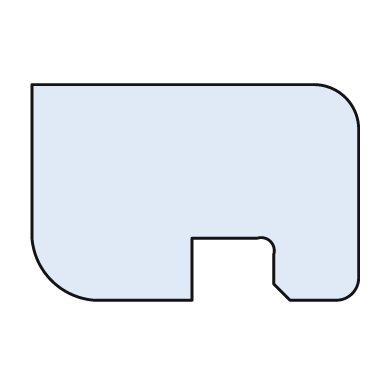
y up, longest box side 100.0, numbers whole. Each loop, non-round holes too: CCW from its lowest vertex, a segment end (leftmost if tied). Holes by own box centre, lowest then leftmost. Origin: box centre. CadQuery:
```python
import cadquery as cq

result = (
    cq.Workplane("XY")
    .moveTo(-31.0, -33.0)
    .lineTo(-1.0, -33.0)
    .lineTo(-1.0, -14.0)
    .lineTo(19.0, -14.0)
    .threePointArc((23.0, -15.0), (24.0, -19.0))
    .lineTo(24.0, -28.0)
    .lineTo(29.0, -33.0)
    .lineTo(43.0, -33.0)
    .threePointArc((48.0, -31.0), (50.0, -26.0))
    .lineTo(50.0, 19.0)
    .threePointArc((46.0, 29.0), (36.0, 33.0))
    .lineTo(-50.0, 33.0)
    .lineTo(-50.0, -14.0)
    .threePointArc((-44.0, -27.0), (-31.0, -33.0))
    .close()
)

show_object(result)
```